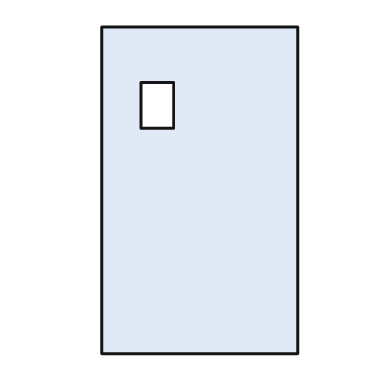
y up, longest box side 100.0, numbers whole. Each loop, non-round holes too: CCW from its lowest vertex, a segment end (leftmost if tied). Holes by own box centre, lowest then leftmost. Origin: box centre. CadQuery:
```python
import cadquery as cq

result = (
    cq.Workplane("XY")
    .moveTo(-30.0, -50.0)
    .lineTo(30.0, -50.0)
    .lineTo(30.0, 50.0)
    .lineTo(-30.0, 50.0)
    .close()
    .moveTo(-18.0, 19.0)
    .lineTo(-8.0, 19.0)
    .lineTo(-8.0, 33.0)
    .lineTo(-18.0, 33.0)
    .close()
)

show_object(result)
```